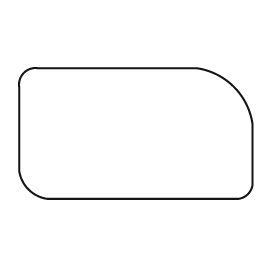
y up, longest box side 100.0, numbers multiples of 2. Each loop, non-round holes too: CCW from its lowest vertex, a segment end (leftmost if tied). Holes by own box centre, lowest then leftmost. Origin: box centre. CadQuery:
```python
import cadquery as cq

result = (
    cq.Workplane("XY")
    .moveTo(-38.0, -28.0)
    .lineTo(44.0, -28.0)
    .threePointArc((48.0, -26.0), (50.0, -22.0))
    .lineTo(50.0, 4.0)
    .threePointArc((42.0, 20.0), (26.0, 28.0))
    .lineTo(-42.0, 28.0)
    .threePointArc((-48.0, 26.0), (-50.0, 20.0))
    .lineTo(-50.0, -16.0)
    .threePointArc((-46.0, -24.0), (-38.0, -28.0))
    .close()
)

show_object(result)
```